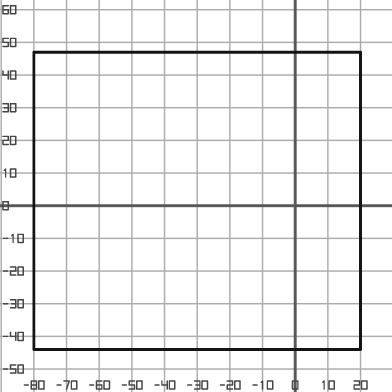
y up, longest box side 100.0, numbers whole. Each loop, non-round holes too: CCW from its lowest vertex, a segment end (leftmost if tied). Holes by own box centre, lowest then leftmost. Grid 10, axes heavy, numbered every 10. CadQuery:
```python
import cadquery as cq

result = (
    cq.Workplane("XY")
    .moveTo(-80.0, -44.0)
    .lineTo(20.0, -44.0)
    .lineTo(20.0, 47.0)
    .lineTo(-80.0, 47.0)
    .close()
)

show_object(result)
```